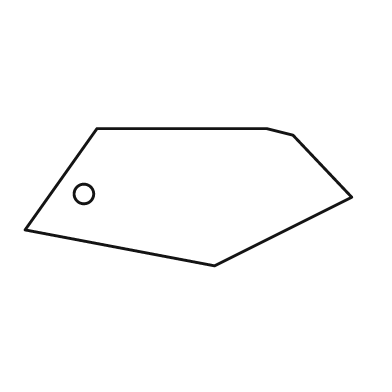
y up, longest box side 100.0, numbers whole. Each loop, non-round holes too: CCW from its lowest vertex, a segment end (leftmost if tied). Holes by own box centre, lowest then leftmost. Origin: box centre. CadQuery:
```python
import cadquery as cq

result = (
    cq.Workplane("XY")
    .moveTo(8.0, -21.0)
    .lineTo(50.0, 0.0)
    .lineTo(32.0, 19.0)
    .lineTo(24.0, 21.0)
    .lineTo(-28.0, 21.0)
    .lineTo(-50.0, -10.0)
    .close()
    .moveTo(-32.0, 1.0)
    .circle(3.0)
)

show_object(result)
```